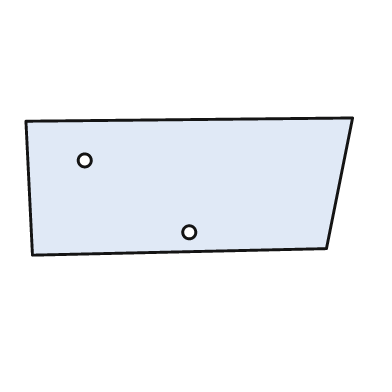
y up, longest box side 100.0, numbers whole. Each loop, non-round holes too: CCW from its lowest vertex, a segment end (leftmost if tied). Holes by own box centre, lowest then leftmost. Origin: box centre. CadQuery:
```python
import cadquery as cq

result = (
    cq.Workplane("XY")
    .moveTo(-48.0, -21.0)
    .lineTo(42.0, -19.0)
    .lineTo(50.0, 21.0)
    .lineTo(-50.0, 20.0)
    .close()
    .moveTo(0.0, -14.0)
    .circle(2.0)
    .moveTo(-32.0, 8.0)
    .circle(2.0)
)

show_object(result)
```